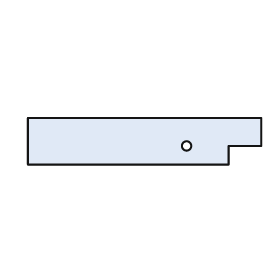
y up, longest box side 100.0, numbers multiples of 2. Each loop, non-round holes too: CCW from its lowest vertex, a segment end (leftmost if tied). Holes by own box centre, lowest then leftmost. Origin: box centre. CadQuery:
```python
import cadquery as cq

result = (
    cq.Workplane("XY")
    .moveTo(-50.0, -10.0)
    .lineTo(36.0, -10.0)
    .lineTo(36.0, -2.0)
    .lineTo(50.0, -2.0)
    .lineTo(50.0, 10.0)
    .lineTo(-50.0, 10.0)
    .close()
    .moveTo(18.0, -2.0)
    .circle(2.0)
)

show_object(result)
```